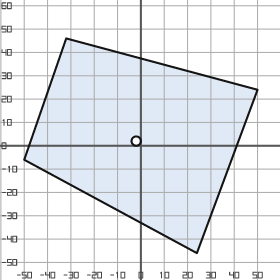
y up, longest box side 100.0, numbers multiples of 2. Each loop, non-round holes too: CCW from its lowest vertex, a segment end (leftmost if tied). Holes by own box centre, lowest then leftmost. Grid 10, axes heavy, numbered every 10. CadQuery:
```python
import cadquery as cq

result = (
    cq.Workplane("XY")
    .moveTo(24.0, -46.0)
    .lineTo(50.0, 24.0)
    .lineTo(-32.0, 46.0)
    .lineTo(-50.0, -6.0)
    .close()
    .moveTo(-2.0, 2.0)
    .circle(2.0)
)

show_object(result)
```